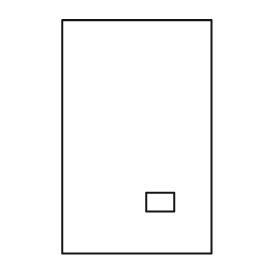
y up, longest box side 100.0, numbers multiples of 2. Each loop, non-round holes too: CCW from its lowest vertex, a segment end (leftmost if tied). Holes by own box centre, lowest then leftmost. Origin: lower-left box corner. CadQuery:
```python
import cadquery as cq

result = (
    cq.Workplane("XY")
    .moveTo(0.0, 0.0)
    .lineTo(64.0, 0.0)
    .lineTo(64.0, 100.0)
    .lineTo(0.0, 100.0)
    .close()
    .moveTo(36.0, 18.0)
    .lineTo(48.0, 18.0)
    .lineTo(48.0, 26.0)
    .lineTo(36.0, 26.0)
    .close()
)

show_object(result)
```